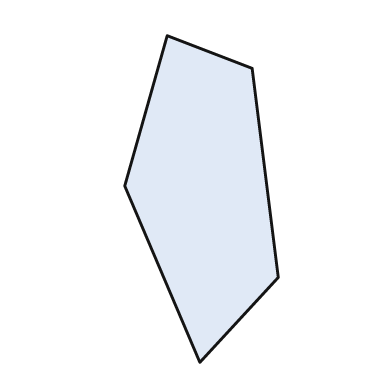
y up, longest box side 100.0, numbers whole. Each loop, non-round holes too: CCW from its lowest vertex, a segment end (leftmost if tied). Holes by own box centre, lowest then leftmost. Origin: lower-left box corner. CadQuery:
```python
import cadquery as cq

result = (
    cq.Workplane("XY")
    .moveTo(23.0, 0.0)
    .lineTo(47.0, 26.0)
    .lineTo(39.0, 90.0)
    .lineTo(13.0, 100.0)
    .lineTo(0.0, 54.0)
    .close()
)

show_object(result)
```